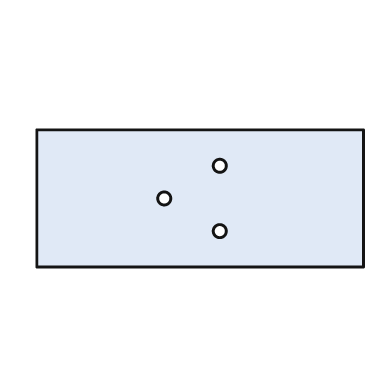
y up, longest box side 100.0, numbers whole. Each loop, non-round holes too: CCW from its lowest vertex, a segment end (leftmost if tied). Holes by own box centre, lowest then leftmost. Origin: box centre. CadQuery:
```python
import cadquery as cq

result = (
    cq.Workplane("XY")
    .moveTo(-50.0, -21.0)
    .lineTo(50.0, -21.0)
    .lineTo(50.0, 21.0)
    .lineTo(-50.0, 21.0)
    .close()
    .moveTo(6.0, -10.0)
    .circle(2.0)
    .moveTo(-11.0, 0.0)
    .circle(2.0)
    .moveTo(6.0, 10.0)
    .circle(2.0)
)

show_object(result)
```